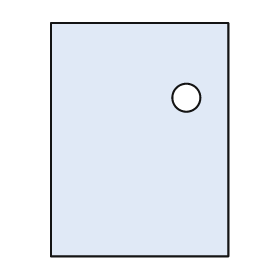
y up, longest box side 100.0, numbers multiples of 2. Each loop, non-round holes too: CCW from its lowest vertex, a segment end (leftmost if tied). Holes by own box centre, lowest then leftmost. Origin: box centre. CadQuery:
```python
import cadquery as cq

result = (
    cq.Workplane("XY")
    .moveTo(-38.0, -50.0)
    .lineTo(38.0, -50.0)
    .lineTo(38.0, 50.0)
    .lineTo(-38.0, 50.0)
    .close()
    .moveTo(20.0, 18.0)
    .circle(6.0)
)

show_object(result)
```